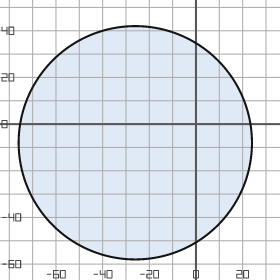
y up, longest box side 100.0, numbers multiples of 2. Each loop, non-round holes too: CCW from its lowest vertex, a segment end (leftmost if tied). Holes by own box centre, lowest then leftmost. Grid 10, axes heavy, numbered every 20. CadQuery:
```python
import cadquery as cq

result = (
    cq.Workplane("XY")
    .moveTo(-26.0, -8.0)
    .circle(50.0)
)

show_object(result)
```